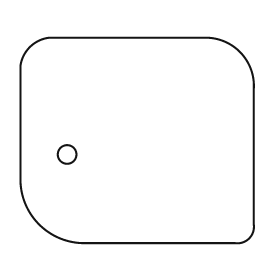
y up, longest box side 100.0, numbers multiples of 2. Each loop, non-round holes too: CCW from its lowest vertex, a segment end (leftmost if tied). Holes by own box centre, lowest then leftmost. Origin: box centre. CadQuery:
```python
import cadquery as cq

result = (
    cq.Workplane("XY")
    .moveTo(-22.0, -44.0)
    .lineTo(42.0, -44.0)
    .threePointArc((48.0, -42.0), (50.0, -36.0))
    .lineTo(50.0, 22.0)
    .threePointArc((44.0, 38.0), (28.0, 44.0))
    .lineTo(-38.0, 44.0)
    .threePointArc((-46.0, 40.0), (-50.0, 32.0))
    .lineTo(-50.0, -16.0)
    .threePointArc((-42.0, -36.0), (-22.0, -44.0))
    .close()
    .moveTo(-30.0, -6.0)
    .circle(4.0)
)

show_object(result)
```